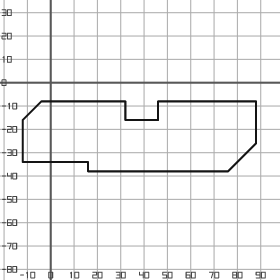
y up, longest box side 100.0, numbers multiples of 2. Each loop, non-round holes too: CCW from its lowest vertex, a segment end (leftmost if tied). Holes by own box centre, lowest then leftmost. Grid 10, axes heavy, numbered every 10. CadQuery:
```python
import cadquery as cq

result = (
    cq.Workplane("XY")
    .moveTo(16.0, -38.0)
    .lineTo(76.0, -38.0)
    .lineTo(88.0, -26.0)
    .lineTo(88.0, -8.0)
    .lineTo(46.0, -8.0)
    .lineTo(46.0, -16.0)
    .lineTo(32.0, -16.0)
    .lineTo(32.0, -8.0)
    .lineTo(-4.0, -8.0)
    .lineTo(-12.0, -16.0)
    .lineTo(-12.0, -34.0)
    .lineTo(16.0, -34.0)
    .close()
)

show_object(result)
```